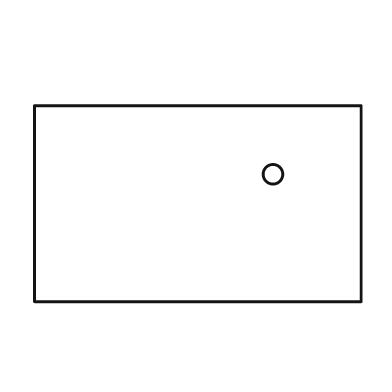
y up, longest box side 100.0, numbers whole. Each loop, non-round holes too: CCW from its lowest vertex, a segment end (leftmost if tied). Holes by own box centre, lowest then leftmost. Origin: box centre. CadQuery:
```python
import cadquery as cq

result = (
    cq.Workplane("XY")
    .moveTo(-50.0, -30.0)
    .lineTo(50.0, -30.0)
    .lineTo(50.0, 30.0)
    .lineTo(-50.0, 30.0)
    .close()
    .moveTo(23.0, 9.0)
    .circle(3.0)
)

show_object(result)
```